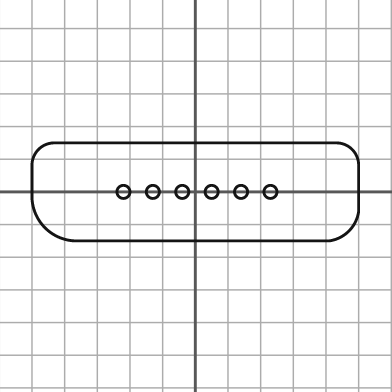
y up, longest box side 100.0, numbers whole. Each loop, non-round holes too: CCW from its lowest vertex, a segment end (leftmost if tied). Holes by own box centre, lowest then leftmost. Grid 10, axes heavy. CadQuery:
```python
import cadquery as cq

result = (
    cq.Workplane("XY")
    .moveTo(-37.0, -15.0)
    .lineTo(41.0, -15.0)
    .threePointArc((47.0, -12.0), (50.0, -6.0))
    .lineTo(50.0, 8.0)
    .threePointArc((48.0, 13.0), (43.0, 15.0))
    .lineTo(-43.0, 15.0)
    .threePointArc((-48.0, 13.0), (-50.0, 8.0))
    .lineTo(-50.0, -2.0)
    .threePointArc((-46.0, -11.0), (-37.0, -15.0))
    .close()
    .moveTo(-22.0, 0.0)
    .circle(2.0)
    .moveTo(-13.0, 0.0)
    .circle(2.0)
    .moveTo(-4.0, 0.0)
    .circle(2.0)
    .moveTo(5.0, 0.0)
    .circle(2.0)
    .moveTo(14.0, 0.0)
    .circle(2.0)
    .moveTo(23.0, 0.0)
    .circle(2.0)
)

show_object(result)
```